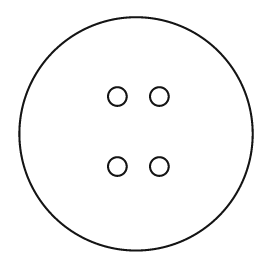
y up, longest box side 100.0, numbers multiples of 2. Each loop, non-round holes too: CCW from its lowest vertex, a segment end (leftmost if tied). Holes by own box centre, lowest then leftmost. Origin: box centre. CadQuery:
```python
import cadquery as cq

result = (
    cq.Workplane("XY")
    .moveTo(0.0, 0.0)
    .circle(50.0)
    .moveTo(-8.0, -14.0)
    .circle(4.0)
    .moveTo(10.0, -14.0)
    .circle(4.0)
    .moveTo(-8.0, 16.0)
    .circle(4.0)
    .moveTo(10.0, 16.0)
    .circle(4.0)
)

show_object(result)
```